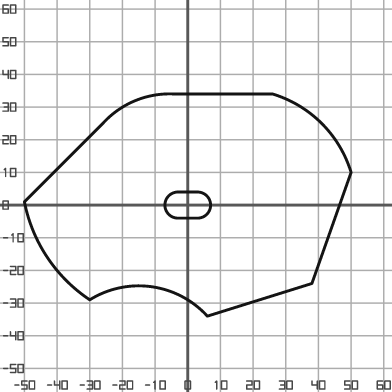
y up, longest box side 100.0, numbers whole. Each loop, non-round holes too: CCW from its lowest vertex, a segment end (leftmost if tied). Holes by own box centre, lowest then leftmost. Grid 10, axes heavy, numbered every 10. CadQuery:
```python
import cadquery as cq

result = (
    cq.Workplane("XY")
    .moveTo(6.0, -34.0)
    .lineTo(38.0, -24.0)
    .lineTo(50.0, 10.0)
    .threePointArc((41.0, 25.0), (26.0, 34.0))
    .lineTo(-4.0, 34.0)
    .threePointArc((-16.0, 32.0), (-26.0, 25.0))
    .lineTo(-50.0, 1.0)
    .threePointArc((-43.0, -16.0), (-30.0, -29.0))
    .threePointArc((-11.0, -25.0), (6.0, -34.0))
    .close()
    .moveTo(-3.0, -4.0)
    .lineTo(3.0, -4.0)
    .threePointArc((7.0, 0.0), (3.0, 4.0))
    .lineTo(-3.0, 4.0)
    .threePointArc((-7.0, 0.0), (-3.0, -4.0))
    .close()
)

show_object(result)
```